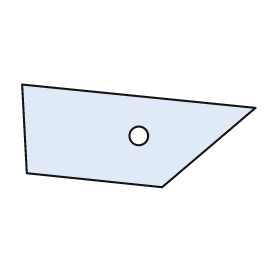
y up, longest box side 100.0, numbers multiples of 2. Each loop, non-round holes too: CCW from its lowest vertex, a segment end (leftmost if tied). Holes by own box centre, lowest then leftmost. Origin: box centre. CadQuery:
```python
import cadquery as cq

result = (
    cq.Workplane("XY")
    .moveTo(10.0, -22.0)
    .lineTo(50.0, 12.0)
    .lineTo(-50.0, 22.0)
    .lineTo(-48.0, -16.0)
    .close()
    .moveTo(0.0, 0.0)
    .circle(4.0)
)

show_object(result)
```